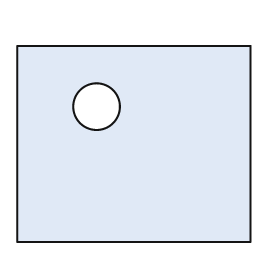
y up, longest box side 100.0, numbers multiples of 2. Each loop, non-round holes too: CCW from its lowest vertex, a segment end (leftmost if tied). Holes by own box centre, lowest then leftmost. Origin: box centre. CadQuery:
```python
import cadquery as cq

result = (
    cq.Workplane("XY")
    .moveTo(-50.0, -42.0)
    .lineTo(50.0, -42.0)
    .lineTo(50.0, 42.0)
    .lineTo(-50.0, 42.0)
    .close()
    .moveTo(-16.0, 16.0)
    .circle(10.0)
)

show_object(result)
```